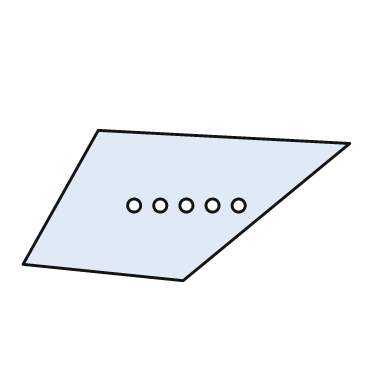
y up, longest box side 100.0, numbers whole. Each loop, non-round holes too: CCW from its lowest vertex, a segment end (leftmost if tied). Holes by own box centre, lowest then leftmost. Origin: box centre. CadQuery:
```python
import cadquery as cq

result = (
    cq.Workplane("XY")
    .moveTo(-1.0, -23.0)
    .lineTo(50.0, 19.0)
    .lineTo(-27.0, 23.0)
    .lineTo(-50.0, -18.0)
    .close()
    .moveTo(-16.0, 0.0)
    .circle(2.0)
    .moveTo(-8.0, 0.0)
    .circle(2.0)
    .moveTo(0.0, 0.0)
    .circle(2.0)
    .moveTo(8.0, 0.0)
    .circle(2.0)
    .moveTo(16.0, 0.0)
    .circle(2.0)
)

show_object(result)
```